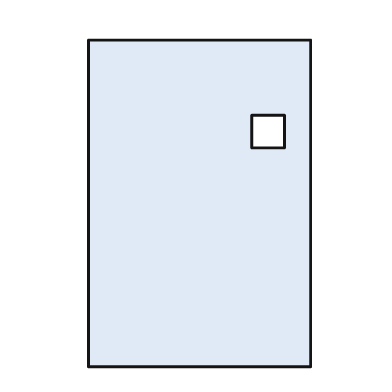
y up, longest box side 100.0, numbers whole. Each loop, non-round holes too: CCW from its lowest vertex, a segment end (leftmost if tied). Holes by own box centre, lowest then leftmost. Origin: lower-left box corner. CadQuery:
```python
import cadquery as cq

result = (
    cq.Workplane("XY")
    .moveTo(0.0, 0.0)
    .lineTo(68.0, 0.0)
    .lineTo(68.0, 100.0)
    .lineTo(0.0, 100.0)
    .close()
    .moveTo(50.0, 67.0)
    .lineTo(60.0, 67.0)
    .lineTo(60.0, 77.0)
    .lineTo(50.0, 77.0)
    .close()
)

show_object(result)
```